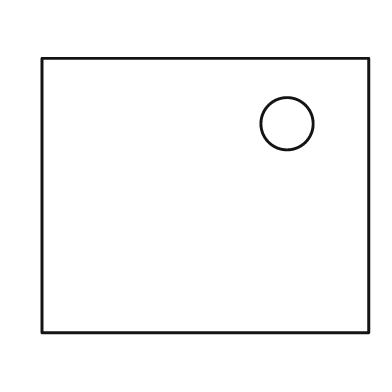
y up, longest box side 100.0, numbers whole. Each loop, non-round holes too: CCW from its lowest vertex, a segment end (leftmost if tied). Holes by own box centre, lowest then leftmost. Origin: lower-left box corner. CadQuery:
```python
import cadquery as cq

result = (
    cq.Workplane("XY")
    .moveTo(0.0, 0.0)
    .lineTo(100.0, 0.0)
    .lineTo(100.0, 84.0)
    .lineTo(0.0, 84.0)
    .close()
    .moveTo(75.0, 64.0)
    .circle(8.0)
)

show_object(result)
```